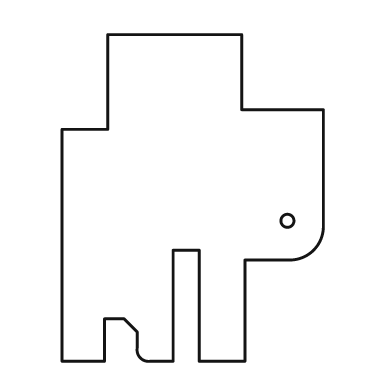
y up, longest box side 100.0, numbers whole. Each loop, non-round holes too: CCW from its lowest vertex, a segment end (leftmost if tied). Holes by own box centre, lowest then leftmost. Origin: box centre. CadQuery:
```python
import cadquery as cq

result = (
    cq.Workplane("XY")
    .moveTo(-40.0, -50.0)
    .lineTo(-27.0, -50.0)
    .lineTo(-27.0, -37.0)
    .lineTo(-21.0, -37.0)
    .lineTo(-17.0, -41.0)
    .lineTo(-17.0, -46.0)
    .threePointArc((-16.0, -49.0), (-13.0, -50.0))
    .lineTo(-6.0, -50.0)
    .lineTo(-6.0, -16.0)
    .lineTo(2.0, -16.0)
    .lineTo(2.0, -50.0)
    .lineTo(16.0, -50.0)
    .lineTo(16.0, -19.0)
    .lineTo(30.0, -19.0)
    .threePointArc((37.0, -16.0), (40.0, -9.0))
    .lineTo(40.0, 27.0)
    .lineTo(15.0, 27.0)
    .lineTo(15.0, 50.0)
    .lineTo(-26.0, 50.0)
    .lineTo(-26.0, 21.0)
    .lineTo(-40.0, 21.0)
    .close()
    .moveTo(29.0, -7.0)
    .circle(2.0)
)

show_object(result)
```